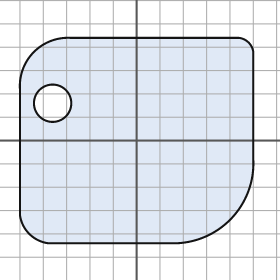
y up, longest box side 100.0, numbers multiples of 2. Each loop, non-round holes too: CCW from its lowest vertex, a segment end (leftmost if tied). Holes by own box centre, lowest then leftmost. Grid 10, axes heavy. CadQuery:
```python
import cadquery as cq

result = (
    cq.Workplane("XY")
    .moveTo(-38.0, -44.0)
    .lineTo(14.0, -44.0)
    .threePointArc((40.0, -34.0), (50.0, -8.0))
    .lineTo(50.0, 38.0)
    .threePointArc((48.0, 42.0), (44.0, 44.0))
    .lineTo(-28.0, 44.0)
    .threePointArc((-44.0, 38.0), (-50.0, 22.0))
    .lineTo(-50.0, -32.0)
    .threePointArc((-46.0, -40.0), (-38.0, -44.0))
    .close()
    .moveTo(-36.0, 16.0)
    .circle(8.0)
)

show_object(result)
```